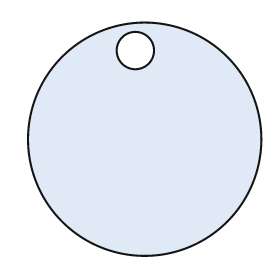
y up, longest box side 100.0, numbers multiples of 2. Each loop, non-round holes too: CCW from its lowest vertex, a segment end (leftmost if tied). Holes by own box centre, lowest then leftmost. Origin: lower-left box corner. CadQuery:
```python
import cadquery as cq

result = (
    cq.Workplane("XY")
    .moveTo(50.0, 50.0)
    .circle(50.0)
    .moveTo(46.0, 88.0)
    .circle(8.0)
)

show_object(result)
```